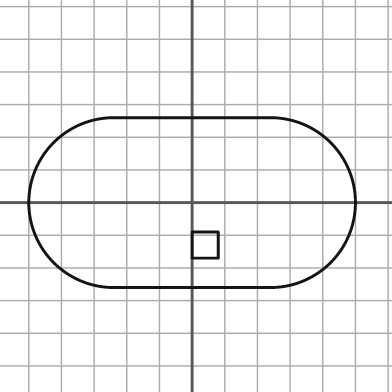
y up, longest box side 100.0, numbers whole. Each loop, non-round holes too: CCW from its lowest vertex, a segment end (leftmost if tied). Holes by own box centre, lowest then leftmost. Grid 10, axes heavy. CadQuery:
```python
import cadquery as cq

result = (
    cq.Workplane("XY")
    .moveTo(-24.0, -26.0)
    .lineTo(24.0, -26.0)
    .threePointArc((50.0, 0.0), (24.0, 26.0))
    .lineTo(-24.0, 26.0)
    .threePointArc((-50.0, 0.0), (-24.0, -26.0))
    .close()
    .moveTo(0.0, -17.0)
    .lineTo(8.0, -17.0)
    .lineTo(8.0, -9.0)
    .lineTo(0.0, -9.0)
    .close()
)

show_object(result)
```